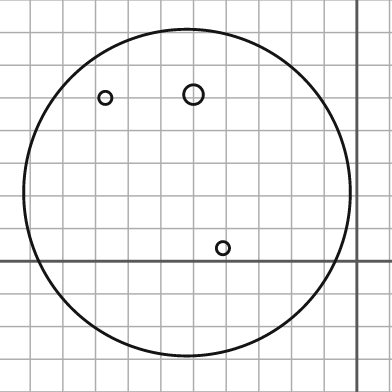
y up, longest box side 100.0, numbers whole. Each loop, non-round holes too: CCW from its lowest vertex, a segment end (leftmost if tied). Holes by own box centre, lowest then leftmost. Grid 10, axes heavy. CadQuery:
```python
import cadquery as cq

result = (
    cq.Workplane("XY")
    .moveTo(-52.0, 21.0)
    .circle(50.0)
    .moveTo(-41.0, 4.0)
    .circle(2.0)
    .moveTo(-77.0, 50.0)
    .circle(2.0)
    .moveTo(-50.0, 51.0)
    .circle(3.0)
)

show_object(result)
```